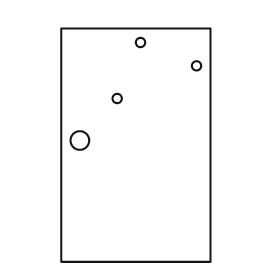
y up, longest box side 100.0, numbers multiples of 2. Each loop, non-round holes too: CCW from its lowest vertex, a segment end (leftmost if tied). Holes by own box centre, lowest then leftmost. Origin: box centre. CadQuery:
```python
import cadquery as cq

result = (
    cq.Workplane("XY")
    .moveTo(-32.0, -50.0)
    .lineTo(32.0, -50.0)
    .lineTo(32.0, 50.0)
    .lineTo(-32.0, 50.0)
    .close()
    .moveTo(-24.0, 2.0)
    .circle(4.0)
    .moveTo(-8.0, 20.0)
    .circle(2.0)
    .moveTo(26.0, 34.0)
    .circle(2.0)
    .moveTo(2.0, 44.0)
    .circle(2.0)
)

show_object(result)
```